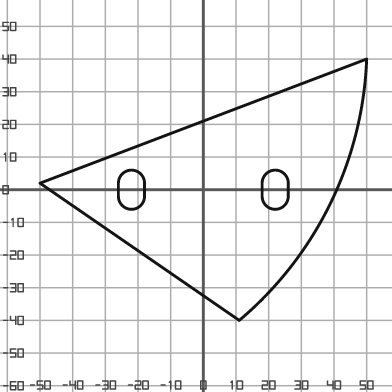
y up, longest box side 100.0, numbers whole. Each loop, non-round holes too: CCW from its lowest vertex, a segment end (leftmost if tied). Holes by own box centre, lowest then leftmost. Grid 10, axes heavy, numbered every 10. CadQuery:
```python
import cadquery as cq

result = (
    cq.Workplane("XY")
    .moveTo(11.0, -40.0)
    .threePointArc((39.0, -4.0), (50.0, 40.0))
    .lineTo(-50.0, 2.0)
    .close()
    .moveTo(-26.0, -2.0)
    .threePointArc((-22.0, -6.0), (-18.0, -2.0))
    .lineTo(-18.0, 2.0)
    .threePointArc((-22.0, 6.0), (-26.0, 2.0))
    .close()
    .moveTo(18.0, -2.0)
    .threePointArc((22.0, -6.0), (26.0, -2.0))
    .lineTo(26.0, 2.0)
    .threePointArc((22.0, 6.0), (18.0, 2.0))
    .close()
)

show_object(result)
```